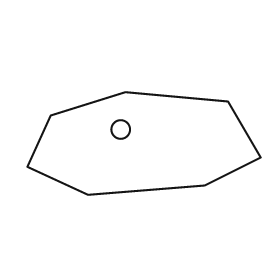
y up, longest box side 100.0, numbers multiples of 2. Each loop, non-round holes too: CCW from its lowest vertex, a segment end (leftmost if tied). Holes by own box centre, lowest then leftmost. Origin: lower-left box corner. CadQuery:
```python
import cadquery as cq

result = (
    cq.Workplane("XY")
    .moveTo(26.0, 0.0)
    .lineTo(76.0, 4.0)
    .lineTo(100.0, 16.0)
    .lineTo(86.0, 40.0)
    .lineTo(42.0, 44.0)
    .lineTo(10.0, 34.0)
    .lineTo(0.0, 12.0)
    .close()
    .moveTo(40.0, 28.0)
    .circle(4.0)
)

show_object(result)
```